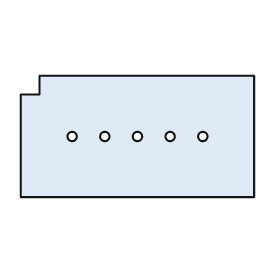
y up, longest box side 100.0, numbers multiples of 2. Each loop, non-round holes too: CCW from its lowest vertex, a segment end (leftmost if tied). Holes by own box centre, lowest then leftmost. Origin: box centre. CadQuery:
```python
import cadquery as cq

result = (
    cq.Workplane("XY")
    .moveTo(-50.0, -26.0)
    .lineTo(50.0, -26.0)
    .lineTo(50.0, 26.0)
    .lineTo(-42.0, 26.0)
    .lineTo(-42.0, 18.0)
    .lineTo(-50.0, 18.0)
    .close()
    .moveTo(-28.0, 0.0)
    .circle(2.0)
    .moveTo(-14.0, 0.0)
    .circle(2.0)
    .moveTo(0.0, 0.0)
    .circle(2.0)
    .moveTo(14.0, 0.0)
    .circle(2.0)
    .moveTo(28.0, 0.0)
    .circle(2.0)
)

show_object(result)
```